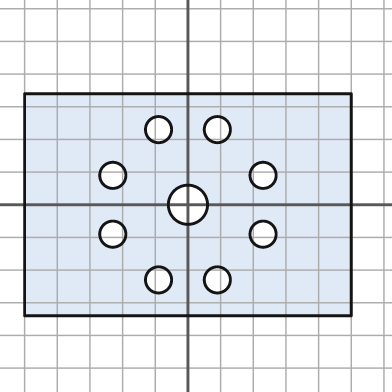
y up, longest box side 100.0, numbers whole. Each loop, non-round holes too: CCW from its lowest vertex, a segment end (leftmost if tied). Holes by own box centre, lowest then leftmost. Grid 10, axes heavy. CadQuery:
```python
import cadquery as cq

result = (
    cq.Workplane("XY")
    .moveTo(-50.0, -34.0)
    .lineTo(50.0, -34.0)
    .lineTo(50.0, 34.0)
    .lineTo(-50.0, 34.0)
    .close()
    .moveTo(-9.0, -23.0)
    .circle(4.0)
    .moveTo(9.0, -23.0)
    .circle(4.0)
    .moveTo(-23.0, -9.0)
    .circle(4.0)
    .moveTo(23.0, -9.0)
    .circle(4.0)
    .moveTo(0.0, 0.0)
    .circle(6.0)
    .moveTo(-23.0, 9.0)
    .circle(4.0)
    .moveTo(23.0, 9.0)
    .circle(4.0)
    .moveTo(-9.0, 23.0)
    .circle(4.0)
    .moveTo(9.0, 23.0)
    .circle(4.0)
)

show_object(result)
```